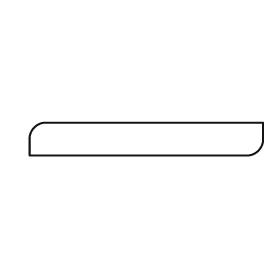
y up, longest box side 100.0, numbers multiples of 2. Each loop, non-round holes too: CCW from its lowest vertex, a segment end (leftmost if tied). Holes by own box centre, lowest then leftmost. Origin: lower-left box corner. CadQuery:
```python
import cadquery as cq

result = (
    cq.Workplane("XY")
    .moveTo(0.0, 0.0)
    .lineTo(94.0, 0.0)
    .threePointArc((98.0, 2.0), (100.0, 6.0))
    .lineTo(100.0, 14.0)
    .lineTo(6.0, 14.0)
    .threePointArc((2.0, 12.0), (0.0, 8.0))
    .close()
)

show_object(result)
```